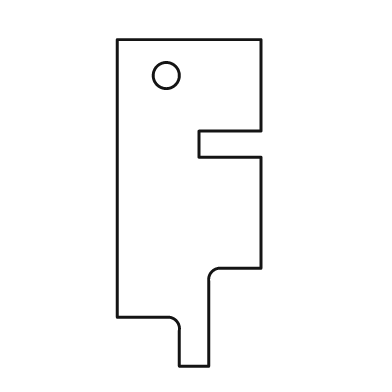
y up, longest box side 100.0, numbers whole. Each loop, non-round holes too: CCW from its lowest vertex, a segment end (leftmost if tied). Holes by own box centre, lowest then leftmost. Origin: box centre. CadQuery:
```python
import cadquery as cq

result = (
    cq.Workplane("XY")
    .moveTo(-3.0, -50.0)
    .lineTo(6.0, -50.0)
    .lineTo(6.0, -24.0)
    .threePointArc((7.0, -21.0), (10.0, -20.0))
    .lineTo(22.0, -20.0)
    .lineTo(22.0, 14.0)
    .lineTo(3.0, 14.0)
    .lineTo(3.0, 22.0)
    .lineTo(22.0, 22.0)
    .lineTo(22.0, 50.0)
    .lineTo(-22.0, 50.0)
    .lineTo(-22.0, -35.0)
    .lineTo(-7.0, -35.0)
    .threePointArc((-4.0, -36.0), (-3.0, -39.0))
    .close()
    .moveTo(-7.0, 39.0)
    .circle(4.0)
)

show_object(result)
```